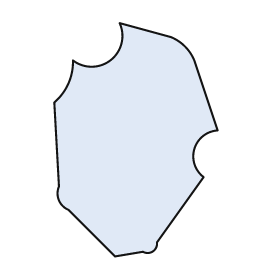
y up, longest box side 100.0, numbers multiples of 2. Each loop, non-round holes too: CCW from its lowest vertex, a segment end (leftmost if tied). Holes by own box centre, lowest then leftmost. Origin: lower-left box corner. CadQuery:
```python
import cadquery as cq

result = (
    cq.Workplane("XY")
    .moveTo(26.0, 0.0)
    .lineTo(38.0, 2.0)
    .threePointArc((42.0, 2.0), (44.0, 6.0))
    .lineTo(64.0, 34.0)
    .threePointArc((60.0, 46.0), (70.0, 54.0))
    .lineTo(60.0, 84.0)
    .threePointArc((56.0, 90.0), (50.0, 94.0))
    .lineTo(28.0, 100.0)
    .threePointArc((24.0, 84.0), (8.0, 84.0))
    .threePointArc((6.0, 74.0), (0.0, 66.0))
    .lineTo(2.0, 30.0)
    .threePointArc((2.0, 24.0), (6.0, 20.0))
    .close()
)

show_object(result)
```